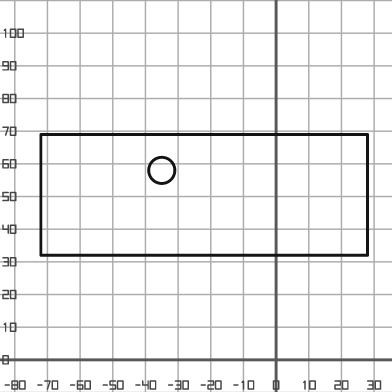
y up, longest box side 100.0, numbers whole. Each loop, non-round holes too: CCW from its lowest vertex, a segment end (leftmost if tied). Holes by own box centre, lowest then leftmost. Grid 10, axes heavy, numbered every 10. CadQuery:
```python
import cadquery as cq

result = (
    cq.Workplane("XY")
    .moveTo(-72.0, 32.0)
    .lineTo(28.0, 32.0)
    .lineTo(28.0, 69.0)
    .lineTo(-72.0, 69.0)
    .close()
    .moveTo(-35.0, 58.0)
    .circle(4.0)
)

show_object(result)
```